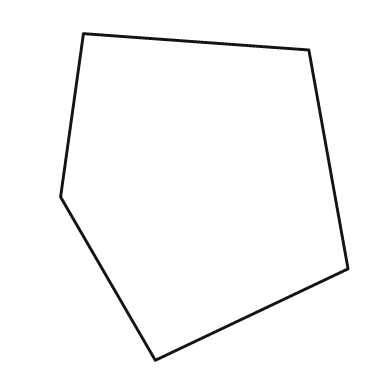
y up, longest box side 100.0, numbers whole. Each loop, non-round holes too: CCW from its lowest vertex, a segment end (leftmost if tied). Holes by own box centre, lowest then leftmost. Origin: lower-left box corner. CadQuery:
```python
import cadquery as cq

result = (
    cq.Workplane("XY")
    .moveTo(29.0, 0.0)
    .lineTo(88.0, 28.0)
    .lineTo(76.0, 95.0)
    .lineTo(7.0, 100.0)
    .lineTo(0.0, 50.0)
    .close()
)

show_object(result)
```